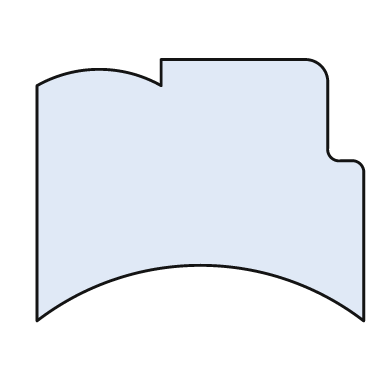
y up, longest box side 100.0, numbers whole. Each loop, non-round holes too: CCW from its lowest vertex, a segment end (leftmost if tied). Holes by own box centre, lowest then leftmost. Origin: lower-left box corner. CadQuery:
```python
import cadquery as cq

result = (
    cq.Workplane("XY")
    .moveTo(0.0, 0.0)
    .threePointArc((50.0, 17.0), (100.0, 0.0))
    .lineTo(100.0, 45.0)
    .threePointArc((99.0, 48.0), (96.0, 49.0))
    .lineTo(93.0, 49.0)
    .threePointArc((90.0, 50.0), (89.0, 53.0))
    .lineTo(89.0, 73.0)
    .threePointArc((87.0, 78.0), (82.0, 80.0))
    .lineTo(38.0, 80.0)
    .lineTo(38.0, 72.0)
    .threePointArc((19.0, 77.0), (0.0, 72.0))
    .close()
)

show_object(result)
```